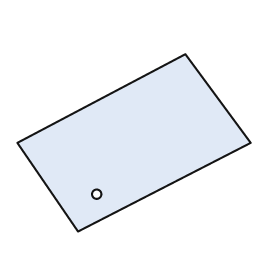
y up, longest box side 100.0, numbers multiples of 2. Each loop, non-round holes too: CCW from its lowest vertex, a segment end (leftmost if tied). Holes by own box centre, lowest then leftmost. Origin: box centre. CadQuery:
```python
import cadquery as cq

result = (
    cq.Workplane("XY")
    .moveTo(-24.0, -38.0)
    .lineTo(50.0, 0.0)
    .lineTo(22.0, 38.0)
    .lineTo(-50.0, 0.0)
    .close()
    .moveTo(-16.0, -22.0)
    .circle(2.0)
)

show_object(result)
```